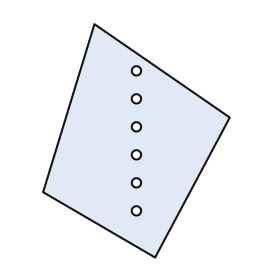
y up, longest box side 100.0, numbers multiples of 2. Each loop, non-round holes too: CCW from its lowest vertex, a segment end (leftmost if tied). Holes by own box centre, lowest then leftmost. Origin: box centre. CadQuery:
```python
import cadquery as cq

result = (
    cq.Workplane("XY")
    .moveTo(8.0, -50.0)
    .lineTo(40.0, 10.0)
    .lineTo(-18.0, 50.0)
    .lineTo(-40.0, -22.0)
    .close()
    .moveTo(0.0, -30.0)
    .circle(2.0)
    .moveTo(0.0, -18.0)
    .circle(2.0)
    .moveTo(0.0, -6.0)
    .circle(2.0)
    .moveTo(0.0, 6.0)
    .circle(2.0)
    .moveTo(0.0, 18.0)
    .circle(2.0)
    .moveTo(0.0, 30.0)
    .circle(2.0)
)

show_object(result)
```